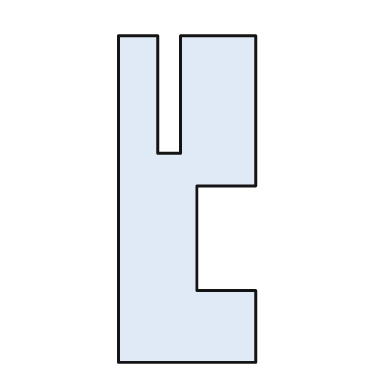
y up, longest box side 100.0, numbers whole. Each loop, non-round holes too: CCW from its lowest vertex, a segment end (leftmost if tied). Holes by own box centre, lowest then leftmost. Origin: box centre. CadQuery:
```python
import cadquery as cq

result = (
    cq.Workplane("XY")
    .moveTo(-21.0, -50.0)
    .lineTo(21.0, -50.0)
    .lineTo(21.0, -28.0)
    .lineTo(3.0, -28.0)
    .lineTo(3.0, 4.0)
    .lineTo(21.0, 4.0)
    .lineTo(21.0, 50.0)
    .lineTo(-2.0, 50.0)
    .lineTo(-2.0, 14.0)
    .lineTo(-9.0, 14.0)
    .lineTo(-9.0, 50.0)
    .lineTo(-21.0, 50.0)
    .close()
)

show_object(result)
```